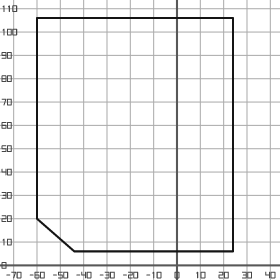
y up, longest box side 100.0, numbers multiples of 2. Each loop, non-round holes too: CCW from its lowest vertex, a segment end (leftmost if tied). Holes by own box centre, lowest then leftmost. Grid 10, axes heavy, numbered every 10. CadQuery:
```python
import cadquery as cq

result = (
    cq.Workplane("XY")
    .moveTo(-44.0, 6.0)
    .lineTo(24.0, 6.0)
    .lineTo(24.0, 106.0)
    .lineTo(-60.0, 106.0)
    .lineTo(-60.0, 20.0)
    .close()
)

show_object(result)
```